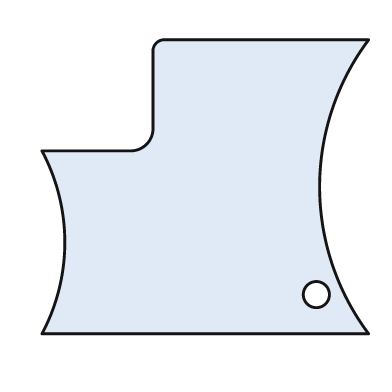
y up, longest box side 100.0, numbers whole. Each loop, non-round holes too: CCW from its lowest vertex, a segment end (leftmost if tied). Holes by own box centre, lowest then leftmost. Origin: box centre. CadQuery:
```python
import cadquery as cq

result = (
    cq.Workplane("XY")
    .moveTo(-50.0, -45.0)
    .lineTo(50.0, -45.0)
    .threePointArc((35.0, 0.0), (50.0, 45.0))
    .lineTo(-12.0, 45.0)
    .threePointArc((-15.0, 44.0), (-16.0, 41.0))
    .lineTo(-16.0, 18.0)
    .threePointArc((-18.0, 13.0), (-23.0, 11.0))
    .lineTo(-50.0, 11.0)
    .threePointArc((-43.0, -17.0), (-50.0, -45.0))
    .close()
    .moveTo(34.0, -33.0)
    .circle(4.0)
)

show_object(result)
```